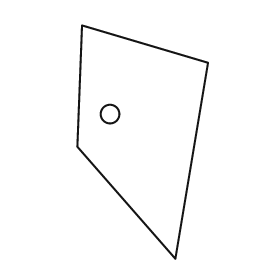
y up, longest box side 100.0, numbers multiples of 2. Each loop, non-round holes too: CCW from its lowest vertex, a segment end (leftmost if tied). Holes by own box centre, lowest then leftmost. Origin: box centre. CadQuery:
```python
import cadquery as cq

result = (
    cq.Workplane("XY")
    .moveTo(14.0, -50.0)
    .lineTo(28.0, 34.0)
    .lineTo(-26.0, 50.0)
    .lineTo(-28.0, -2.0)
    .close()
    .moveTo(-14.0, 12.0)
    .circle(4.0)
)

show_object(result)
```